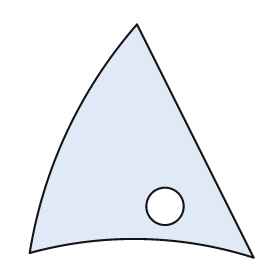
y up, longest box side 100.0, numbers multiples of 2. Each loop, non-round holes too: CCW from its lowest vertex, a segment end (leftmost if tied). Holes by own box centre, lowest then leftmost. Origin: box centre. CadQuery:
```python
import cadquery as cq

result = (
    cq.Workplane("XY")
    .moveTo(48.0, -50.0)
    .lineTo(-2.0, 50.0)
    .threePointArc((-32.0, 4.0), (-48.0, -48.0))
    .threePointArc((0.0, -42.0), (48.0, -50.0))
    .close()
    .moveTo(10.0, -28.0)
    .circle(8.0)
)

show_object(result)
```